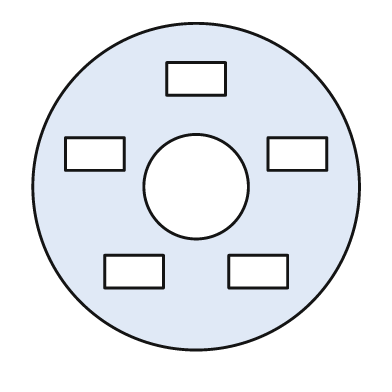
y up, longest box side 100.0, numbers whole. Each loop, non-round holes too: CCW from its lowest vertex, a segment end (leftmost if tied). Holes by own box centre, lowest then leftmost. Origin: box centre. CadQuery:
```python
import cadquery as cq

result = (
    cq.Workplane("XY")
    .moveTo(0.0, 0.0)
    .circle(50.0)
    .moveTo(-28.0, -31.0)
    .lineTo(-10.0, -31.0)
    .lineTo(-10.0, -21.0)
    .lineTo(-28.0, -21.0)
    .close()
    .moveTo(10.0, -31.0)
    .lineTo(28.0, -31.0)
    .lineTo(28.0, -21.0)
    .lineTo(10.0, -21.0)
    .close()
    .moveTo(0.0, 0.0)
    .circle(16.0)
    .moveTo(-40.0, 5.0)
    .lineTo(-22.0, 5.0)
    .lineTo(-22.0, 15.0)
    .lineTo(-40.0, 15.0)
    .close()
    .moveTo(22.0, 5.0)
    .lineTo(40.0, 5.0)
    .lineTo(40.0, 15.0)
    .lineTo(22.0, 15.0)
    .close()
    .moveTo(-9.0, 28.0)
    .lineTo(9.0, 28.0)
    .lineTo(9.0, 38.0)
    .lineTo(-9.0, 38.0)
    .close()
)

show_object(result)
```